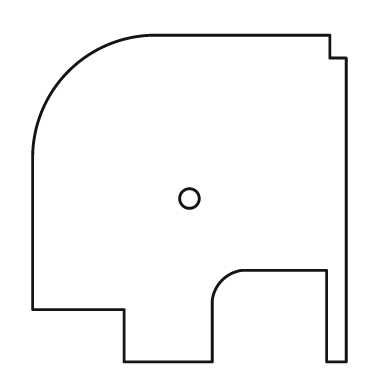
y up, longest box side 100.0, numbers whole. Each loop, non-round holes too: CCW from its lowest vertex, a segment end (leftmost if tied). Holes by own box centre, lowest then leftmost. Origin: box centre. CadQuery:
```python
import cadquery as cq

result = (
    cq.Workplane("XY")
    .moveTo(-20.0, -50.0)
    .lineTo(7.0, -50.0)
    .lineTo(7.0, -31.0)
    .threePointArc((10.0, -25.0), (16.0, -22.0))
    .lineTo(42.0, -22.0)
    .lineTo(42.0, -50.0)
    .lineTo(48.0, -50.0)
    .lineTo(48.0, 43.0)
    .lineTo(43.0, 43.0)
    .lineTo(43.0, 50.0)
    .lineTo(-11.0, 50.0)
    .threePointArc((-37.0, 39.0), (-48.0, 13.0))
    .lineTo(-48.0, -34.0)
    .lineTo(-20.0, -34.0)
    .close()
    .moveTo(0.0, 0.0)
    .circle(3.0)
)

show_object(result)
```